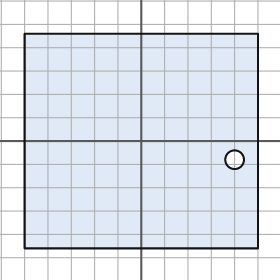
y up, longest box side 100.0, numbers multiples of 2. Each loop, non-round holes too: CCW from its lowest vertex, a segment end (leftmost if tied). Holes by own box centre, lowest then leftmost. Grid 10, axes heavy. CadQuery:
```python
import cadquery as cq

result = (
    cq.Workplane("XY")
    .moveTo(-50.0, -46.0)
    .lineTo(50.0, -46.0)
    .lineTo(50.0, 46.0)
    .lineTo(-50.0, 46.0)
    .close()
    .moveTo(40.0, -8.0)
    .circle(4.0)
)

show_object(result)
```